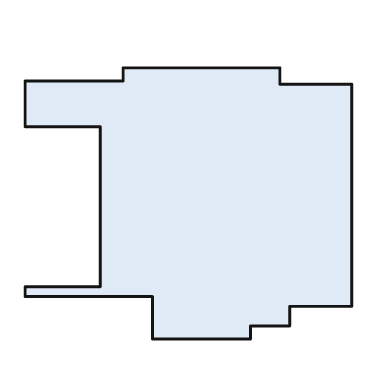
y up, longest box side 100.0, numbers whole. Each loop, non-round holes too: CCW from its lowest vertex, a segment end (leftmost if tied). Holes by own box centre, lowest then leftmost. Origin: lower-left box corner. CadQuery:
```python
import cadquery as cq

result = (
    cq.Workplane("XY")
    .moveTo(39.0, 0.0)
    .lineTo(69.0, 0.0)
    .lineTo(69.0, 4.0)
    .lineTo(81.0, 4.0)
    .lineTo(81.0, 10.0)
    .lineTo(100.0, 10.0)
    .lineTo(100.0, 78.0)
    .lineTo(78.0, 78.0)
    .lineTo(78.0, 83.0)
    .lineTo(30.0, 83.0)
    .lineTo(30.0, 79.0)
    .lineTo(0.0, 79.0)
    .lineTo(0.0, 65.0)
    .lineTo(23.0, 65.0)
    .lineTo(23.0, 16.0)
    .lineTo(0.0, 16.0)
    .lineTo(0.0, 13.0)
    .lineTo(39.0, 13.0)
    .close()
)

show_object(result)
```